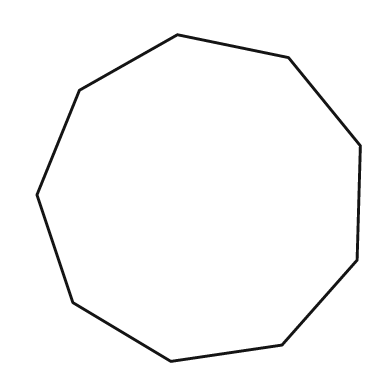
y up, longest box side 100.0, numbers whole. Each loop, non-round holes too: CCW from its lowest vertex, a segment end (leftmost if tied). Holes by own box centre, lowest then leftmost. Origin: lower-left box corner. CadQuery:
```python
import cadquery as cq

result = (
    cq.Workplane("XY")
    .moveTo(41.0, 0.0)
    .lineTo(75.0, 5.0)
    .lineTo(98.0, 31.0)
    .lineTo(99.0, 66.0)
    .lineTo(77.0, 93.0)
    .lineTo(43.0, 100.0)
    .lineTo(13.0, 83.0)
    .lineTo(0.0, 51.0)
    .lineTo(11.0, 18.0)
    .close()
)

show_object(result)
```